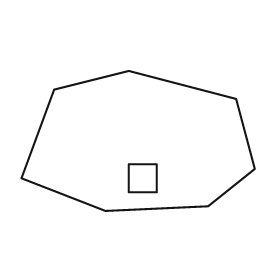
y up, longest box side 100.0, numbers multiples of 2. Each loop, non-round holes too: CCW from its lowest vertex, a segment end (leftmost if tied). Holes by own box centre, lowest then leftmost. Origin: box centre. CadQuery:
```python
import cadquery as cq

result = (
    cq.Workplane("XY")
    .moveTo(-14.0, -30.0)
    .lineTo(30.0, -28.0)
    .lineTo(50.0, -12.0)
    .lineTo(42.0, 18.0)
    .lineTo(-4.0, 30.0)
    .lineTo(-36.0, 22.0)
    .lineTo(-50.0, -16.0)
    .close()
    .moveTo(-4.0, -22.0)
    .lineTo(8.0, -22.0)
    .lineTo(8.0, -10.0)
    .lineTo(-4.0, -10.0)
    .close()
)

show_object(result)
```